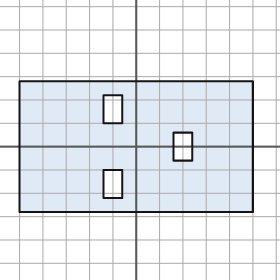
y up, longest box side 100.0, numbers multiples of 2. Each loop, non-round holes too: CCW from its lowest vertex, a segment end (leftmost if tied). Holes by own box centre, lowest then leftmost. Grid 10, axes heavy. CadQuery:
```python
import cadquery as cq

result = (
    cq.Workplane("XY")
    .moveTo(-50.0, -28.0)
    .lineTo(50.0, -28.0)
    .lineTo(50.0, 28.0)
    .lineTo(-50.0, 28.0)
    .close()
    .moveTo(-14.0, -22.0)
    .lineTo(-6.0, -22.0)
    .lineTo(-6.0, -10.0)
    .lineTo(-14.0, -10.0)
    .close()
    .moveTo(16.0, -6.0)
    .lineTo(24.0, -6.0)
    .lineTo(24.0, 6.0)
    .lineTo(16.0, 6.0)
    .close()
    .moveTo(-14.0, 10.0)
    .lineTo(-6.0, 10.0)
    .lineTo(-6.0, 22.0)
    .lineTo(-14.0, 22.0)
    .close()
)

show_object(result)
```